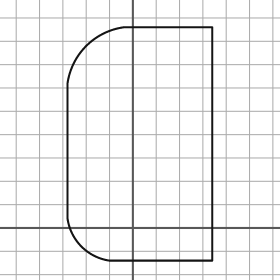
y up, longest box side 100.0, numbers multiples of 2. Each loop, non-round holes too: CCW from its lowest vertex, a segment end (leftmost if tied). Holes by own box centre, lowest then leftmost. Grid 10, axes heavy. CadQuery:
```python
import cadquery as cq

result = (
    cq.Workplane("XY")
    .moveTo(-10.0, -14.0)
    .lineTo(34.0, -14.0)
    .lineTo(34.0, 86.0)
    .lineTo(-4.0, 86.0)
    .threePointArc((-20.0, 78.0), (-28.0, 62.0))
    .lineTo(-28.0, 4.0)
    .threePointArc((-22.0, -8.0), (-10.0, -14.0))
    .close()
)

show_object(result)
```